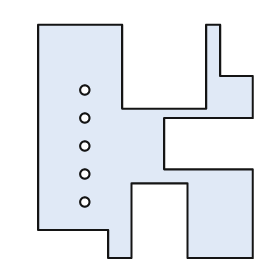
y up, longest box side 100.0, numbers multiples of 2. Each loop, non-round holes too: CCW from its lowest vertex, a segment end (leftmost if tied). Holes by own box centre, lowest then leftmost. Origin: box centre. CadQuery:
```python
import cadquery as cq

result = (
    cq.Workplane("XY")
    .moveTo(-16.0, -50.0)
    .lineTo(-6.0, -50.0)
    .lineTo(-6.0, -18.0)
    .lineTo(18.0, -18.0)
    .lineTo(18.0, -50.0)
    .lineTo(46.0, -50.0)
    .lineTo(46.0, -12.0)
    .lineTo(8.0, -12.0)
    .lineTo(8.0, 10.0)
    .lineTo(46.0, 10.0)
    .lineTo(46.0, 28.0)
    .lineTo(32.0, 28.0)
    .lineTo(32.0, 50.0)
    .lineTo(26.0, 50.0)
    .lineTo(26.0, 14.0)
    .lineTo(-10.0, 14.0)
    .lineTo(-10.0, 50.0)
    .lineTo(-46.0, 50.0)
    .lineTo(-46.0, -38.0)
    .lineTo(-16.0, -38.0)
    .close()
    .moveTo(-26.0, -26.0)
    .circle(2.0)
    .moveTo(-26.0, -14.0)
    .circle(2.0)
    .moveTo(-26.0, -2.0)
    .circle(2.0)
    .moveTo(-26.0, 10.0)
    .circle(2.0)
    .moveTo(-26.0, 22.0)
    .circle(2.0)
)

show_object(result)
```